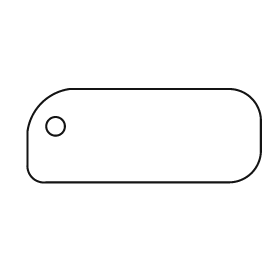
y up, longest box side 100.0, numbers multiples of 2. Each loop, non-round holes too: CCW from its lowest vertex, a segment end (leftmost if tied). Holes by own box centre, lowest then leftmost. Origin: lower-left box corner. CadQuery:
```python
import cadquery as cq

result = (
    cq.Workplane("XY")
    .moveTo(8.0, 0.0)
    .lineTo(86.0, 0.0)
    .threePointArc((96.0, 4.0), (100.0, 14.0))
    .lineTo(100.0, 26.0)
    .threePointArc((96.0, 36.0), (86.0, 40.0))
    .lineTo(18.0, 40.0)
    .threePointArc((6.0, 34.0), (0.0, 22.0))
    .lineTo(0.0, 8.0)
    .threePointArc((2.0, 2.0), (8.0, 0.0))
    .close()
    .moveTo(12.0, 24.0)
    .circle(4.0)
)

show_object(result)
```